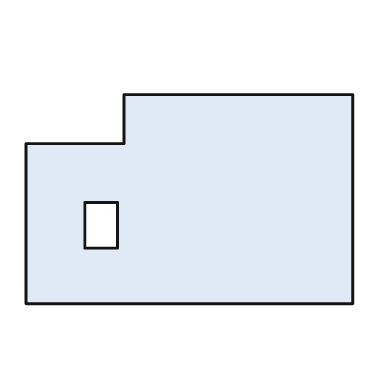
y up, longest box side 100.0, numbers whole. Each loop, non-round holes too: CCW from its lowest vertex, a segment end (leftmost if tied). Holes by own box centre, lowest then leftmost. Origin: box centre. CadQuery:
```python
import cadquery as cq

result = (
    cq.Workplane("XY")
    .moveTo(-50.0, -32.0)
    .lineTo(50.0, -32.0)
    .lineTo(50.0, 32.0)
    .lineTo(-20.0, 32.0)
    .lineTo(-20.0, 17.0)
    .lineTo(-50.0, 17.0)
    .close()
    .moveTo(-32.0, -15.0)
    .lineTo(-22.0, -15.0)
    .lineTo(-22.0, -1.0)
    .lineTo(-32.0, -1.0)
    .close()
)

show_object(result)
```